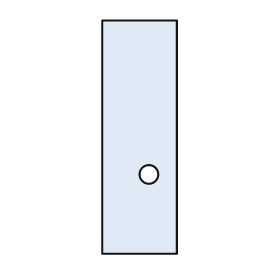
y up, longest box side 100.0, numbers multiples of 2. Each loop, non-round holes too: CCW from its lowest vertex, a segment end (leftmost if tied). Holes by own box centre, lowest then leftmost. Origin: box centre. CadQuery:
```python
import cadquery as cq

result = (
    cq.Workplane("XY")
    .moveTo(-16.0, -50.0)
    .lineTo(16.0, -50.0)
    .lineTo(16.0, 50.0)
    .lineTo(-16.0, 50.0)
    .close()
    .moveTo(4.0, -16.0)
    .circle(4.0)
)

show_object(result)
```